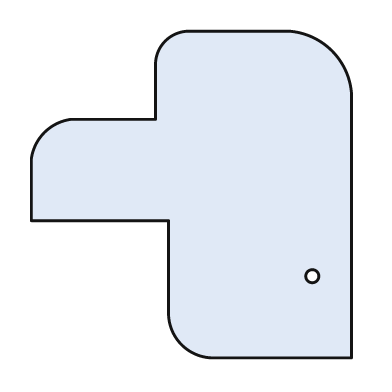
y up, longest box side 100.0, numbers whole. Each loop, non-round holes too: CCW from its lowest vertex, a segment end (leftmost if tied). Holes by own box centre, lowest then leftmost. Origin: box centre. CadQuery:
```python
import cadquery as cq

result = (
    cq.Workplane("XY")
    .moveTo(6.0, -50.0)
    .lineTo(49.0, -50.0)
    .lineTo(49.0, 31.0)
    .threePointArc((43.0, 44.0), (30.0, 50.0))
    .lineTo(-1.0, 50.0)
    .threePointArc((-8.0, 47.0), (-11.0, 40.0))
    .lineTo(-11.0, 23.0)
    .lineTo(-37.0, 23.0)
    .threePointArc((-45.0, 19.0), (-49.0, 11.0))
    .lineTo(-49.0, -8.0)
    .lineTo(-7.0, -8.0)
    .lineTo(-7.0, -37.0)
    .threePointArc((-3.0, -46.0), (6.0, -50.0))
    .close()
    .moveTo(37.0, -25.0)
    .circle(2.0)
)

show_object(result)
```